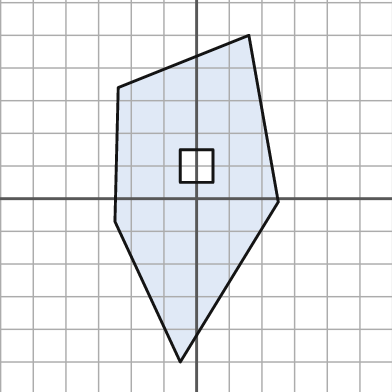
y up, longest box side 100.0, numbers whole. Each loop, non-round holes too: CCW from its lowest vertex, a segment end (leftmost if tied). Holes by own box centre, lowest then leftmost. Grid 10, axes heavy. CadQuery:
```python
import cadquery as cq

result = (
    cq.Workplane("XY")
    .moveTo(-5.0, -50.0)
    .lineTo(25.0, -1.0)
    .lineTo(16.0, 50.0)
    .lineTo(-24.0, 34.0)
    .lineTo(-25.0, -7.0)
    .close()
    .moveTo(-5.0, 5.0)
    .lineTo(5.0, 5.0)
    .lineTo(5.0, 15.0)
    .lineTo(-5.0, 15.0)
    .close()
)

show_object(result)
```